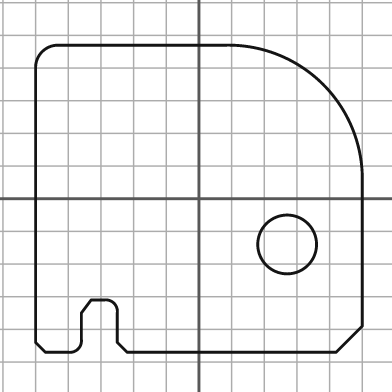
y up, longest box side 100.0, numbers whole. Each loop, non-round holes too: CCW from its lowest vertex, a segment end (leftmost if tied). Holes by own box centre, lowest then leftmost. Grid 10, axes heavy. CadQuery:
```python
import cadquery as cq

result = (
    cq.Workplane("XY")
    .moveTo(-47.0, -47.0)
    .lineTo(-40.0, -47.0)
    .threePointArc((-37.0, -46.0), (-36.0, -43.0))
    .lineTo(-36.0, -35.0)
    .lineTo(-33.0, -31.0)
    .lineTo(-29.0, -31.0)
    .threePointArc((-26.0, -32.0), (-25.0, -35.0))
    .lineTo(-25.0, -44.0)
    .lineTo(-22.0, -47.0)
    .lineTo(42.0, -47.0)
    .lineTo(50.0, -39.0)
    .lineTo(50.0, 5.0)
    .threePointArc((38.0, 35.0), (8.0, 47.0))
    .lineTo(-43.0, 47.0)
    .threePointArc((-48.0, 45.0), (-50.0, 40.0))
    .lineTo(-50.0, -44.0)
    .close()
    .moveTo(27.0, -14.0)
    .circle(9.0)
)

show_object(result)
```